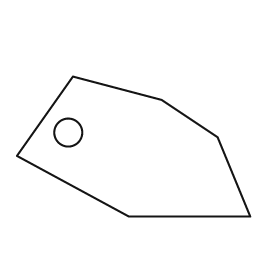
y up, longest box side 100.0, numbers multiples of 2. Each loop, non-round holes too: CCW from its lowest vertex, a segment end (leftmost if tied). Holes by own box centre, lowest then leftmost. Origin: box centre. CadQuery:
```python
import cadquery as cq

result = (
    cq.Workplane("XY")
    .moveTo(-2.0, -30.0)
    .lineTo(50.0, -30.0)
    .lineTo(36.0, 4.0)
    .lineTo(12.0, 20.0)
    .lineTo(-26.0, 30.0)
    .lineTo(-50.0, -4.0)
    .close()
    .moveTo(-28.0, 6.0)
    .circle(6.0)
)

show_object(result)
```